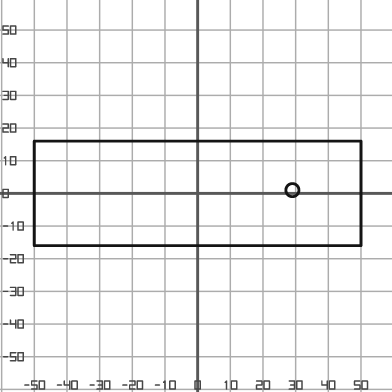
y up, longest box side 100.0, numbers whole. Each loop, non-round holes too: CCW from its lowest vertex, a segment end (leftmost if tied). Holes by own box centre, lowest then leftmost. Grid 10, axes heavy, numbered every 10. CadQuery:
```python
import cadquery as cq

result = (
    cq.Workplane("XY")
    .moveTo(-50.0, -16.0)
    .lineTo(50.0, -16.0)
    .lineTo(50.0, 16.0)
    .lineTo(-50.0, 16.0)
    .close()
    .moveTo(29.0, 1.0)
    .circle(2.0)
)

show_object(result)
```